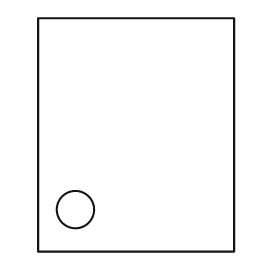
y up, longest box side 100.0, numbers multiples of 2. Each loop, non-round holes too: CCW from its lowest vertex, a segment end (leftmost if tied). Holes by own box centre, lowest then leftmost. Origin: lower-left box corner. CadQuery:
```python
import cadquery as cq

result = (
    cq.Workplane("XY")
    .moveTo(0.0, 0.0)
    .lineTo(84.0, 0.0)
    .lineTo(84.0, 100.0)
    .lineTo(0.0, 100.0)
    .close()
    .moveTo(16.0, 18.0)
    .circle(8.0)
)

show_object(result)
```